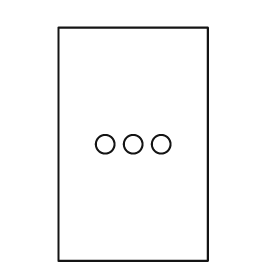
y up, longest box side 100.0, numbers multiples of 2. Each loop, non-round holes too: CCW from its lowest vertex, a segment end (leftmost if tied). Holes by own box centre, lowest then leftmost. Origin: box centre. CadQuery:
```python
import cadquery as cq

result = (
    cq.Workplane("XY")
    .moveTo(-32.0, -50.0)
    .lineTo(32.0, -50.0)
    .lineTo(32.0, 50.0)
    .lineTo(-32.0, 50.0)
    .close()
    .moveTo(-12.0, 0.0)
    .circle(4.0)
    .moveTo(0.0, 0.0)
    .circle(4.0)
    .moveTo(12.0, 0.0)
    .circle(4.0)
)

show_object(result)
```